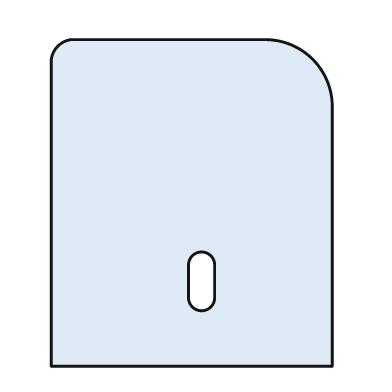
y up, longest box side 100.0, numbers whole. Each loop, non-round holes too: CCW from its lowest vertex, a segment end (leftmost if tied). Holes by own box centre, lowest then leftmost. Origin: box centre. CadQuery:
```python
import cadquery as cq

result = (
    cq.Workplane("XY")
    .moveTo(-43.0, -50.0)
    .lineTo(43.0, -50.0)
    .lineTo(43.0, 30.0)
    .threePointArc((37.0, 44.0), (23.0, 50.0))
    .lineTo(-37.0, 50.0)
    .threePointArc((-41.0, 48.0), (-43.0, 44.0))
    .close()
    .moveTo(-1.0, -29.0)
    .threePointArc((3.0, -33.0), (7.0, -29.0))
    .lineTo(7.0, -19.0)
    .threePointArc((3.0, -15.0), (-1.0, -19.0))
    .close()
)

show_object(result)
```